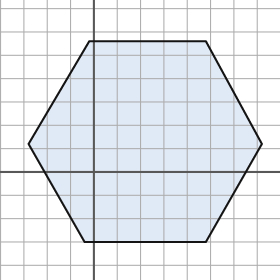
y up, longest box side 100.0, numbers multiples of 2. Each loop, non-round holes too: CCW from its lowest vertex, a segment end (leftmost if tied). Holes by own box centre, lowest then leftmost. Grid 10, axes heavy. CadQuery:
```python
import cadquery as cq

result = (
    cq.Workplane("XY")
    .moveTo(-4.0, -30.0)
    .lineTo(48.0, -30.0)
    .lineTo(72.0, 12.0)
    .lineTo(48.0, 56.0)
    .lineTo(-2.0, 56.0)
    .lineTo(-28.0, 12.0)
    .close()
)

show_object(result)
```